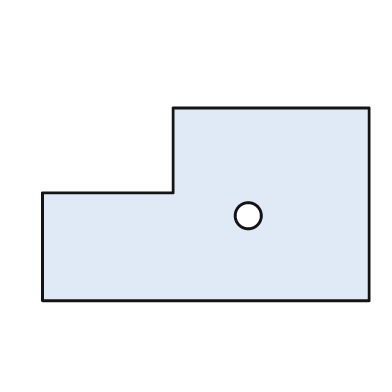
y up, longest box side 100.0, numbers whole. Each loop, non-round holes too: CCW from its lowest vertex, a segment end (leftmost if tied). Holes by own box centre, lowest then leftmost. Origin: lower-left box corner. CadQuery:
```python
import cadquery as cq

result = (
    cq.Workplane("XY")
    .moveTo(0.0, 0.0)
    .lineTo(100.0, 0.0)
    .lineTo(100.0, 59.0)
    .lineTo(40.0, 59.0)
    .lineTo(40.0, 33.0)
    .lineTo(0.0, 33.0)
    .close()
    .moveTo(63.0, 26.0)
    .circle(4.0)
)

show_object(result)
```